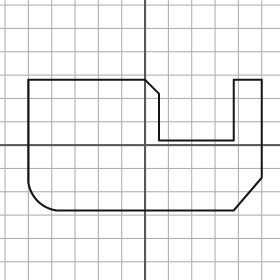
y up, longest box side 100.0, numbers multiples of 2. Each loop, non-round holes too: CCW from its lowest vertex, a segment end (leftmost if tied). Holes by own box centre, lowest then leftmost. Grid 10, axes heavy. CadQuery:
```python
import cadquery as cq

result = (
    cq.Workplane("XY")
    .moveTo(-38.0, -28.0)
    .lineTo(38.0, -28.0)
    .lineTo(50.0, -14.0)
    .lineTo(50.0, 28.0)
    .lineTo(38.0, 28.0)
    .lineTo(38.0, 2.0)
    .lineTo(6.0, 2.0)
    .lineTo(6.0, 22.0)
    .lineTo(0.0, 28.0)
    .lineTo(-50.0, 28.0)
    .lineTo(-50.0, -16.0)
    .threePointArc((-46.0, -24.0), (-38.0, -28.0))
    .close()
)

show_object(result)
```